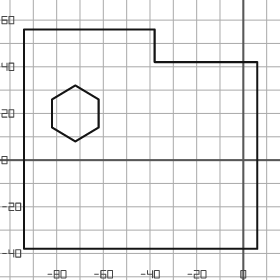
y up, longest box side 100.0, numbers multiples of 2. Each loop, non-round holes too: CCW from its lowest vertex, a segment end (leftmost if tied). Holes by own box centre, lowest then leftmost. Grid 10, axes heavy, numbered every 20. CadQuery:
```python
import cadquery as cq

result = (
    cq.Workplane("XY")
    .moveTo(-94.0, -38.0)
    .lineTo(6.0, -38.0)
    .lineTo(6.0, 42.0)
    .lineTo(-38.0, 42.0)
    .lineTo(-38.0, 56.0)
    .lineTo(-94.0, 56.0)
    .close()
    .moveTo(-72.0, 8.0)
    .lineTo(-62.0, 14.0)
    .lineTo(-62.0, 26.0)
    .lineTo(-72.0, 32.0)
    .lineTo(-82.0, 26.0)
    .lineTo(-82.0, 14.0)
    .close()
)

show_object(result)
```